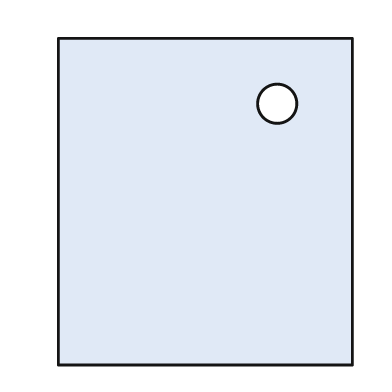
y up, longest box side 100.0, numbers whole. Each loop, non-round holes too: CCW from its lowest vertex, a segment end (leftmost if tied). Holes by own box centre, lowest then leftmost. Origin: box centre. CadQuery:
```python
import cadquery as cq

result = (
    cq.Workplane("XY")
    .moveTo(-45.0, -50.0)
    .lineTo(45.0, -50.0)
    .lineTo(45.0, 50.0)
    .lineTo(-45.0, 50.0)
    .close()
    .moveTo(22.0, 30.0)
    .circle(6.0)
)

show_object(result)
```